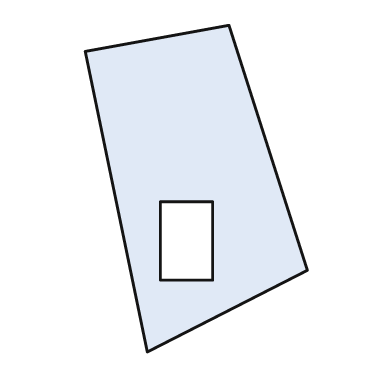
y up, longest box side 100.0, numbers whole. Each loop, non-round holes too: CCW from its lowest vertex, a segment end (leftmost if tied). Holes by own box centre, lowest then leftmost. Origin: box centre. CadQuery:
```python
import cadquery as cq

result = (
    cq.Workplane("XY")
    .moveTo(-15.0, -50.0)
    .lineTo(34.0, -25.0)
    .lineTo(10.0, 50.0)
    .lineTo(-34.0, 42.0)
    .close()
    .moveTo(-11.0, -28.0)
    .lineTo(5.0, -28.0)
    .lineTo(5.0, -4.0)
    .lineTo(-11.0, -4.0)
    .close()
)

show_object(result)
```